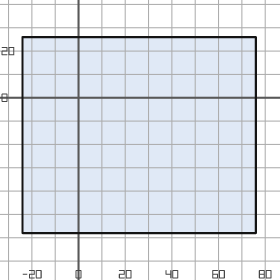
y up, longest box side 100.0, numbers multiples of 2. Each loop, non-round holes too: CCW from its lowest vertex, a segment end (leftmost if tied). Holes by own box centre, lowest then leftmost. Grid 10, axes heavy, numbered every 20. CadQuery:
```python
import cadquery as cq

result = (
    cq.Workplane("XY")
    .moveTo(-24.0, -58.0)
    .lineTo(76.0, -58.0)
    .lineTo(76.0, 26.0)
    .lineTo(-24.0, 26.0)
    .close()
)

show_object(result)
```